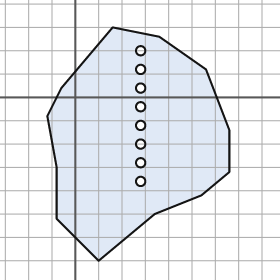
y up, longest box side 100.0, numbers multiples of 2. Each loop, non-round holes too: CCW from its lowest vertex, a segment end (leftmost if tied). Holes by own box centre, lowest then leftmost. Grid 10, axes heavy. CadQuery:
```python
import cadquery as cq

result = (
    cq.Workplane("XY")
    .moveTo(10.0, -70.0)
    .lineTo(34.0, -50.0)
    .lineTo(54.0, -42.0)
    .lineTo(66.0, -32.0)
    .lineTo(66.0, -14.0)
    .lineTo(56.0, 12.0)
    .lineTo(36.0, 26.0)
    .lineTo(16.0, 30.0)
    .lineTo(-6.0, 4.0)
    .lineTo(-12.0, -8.0)
    .lineTo(-8.0, -30.0)
    .lineTo(-8.0, -52.0)
    .close()
    .moveTo(28.0, -36.0)
    .circle(2.0)
    .moveTo(28.0, -28.0)
    .circle(2.0)
    .moveTo(28.0, -20.0)
    .circle(2.0)
    .moveTo(28.0, -12.0)
    .circle(2.0)
    .moveTo(28.0, -4.0)
    .circle(2.0)
    .moveTo(28.0, 4.0)
    .circle(2.0)
    .moveTo(28.0, 12.0)
    .circle(2.0)
    .moveTo(28.0, 20.0)
    .circle(2.0)
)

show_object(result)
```